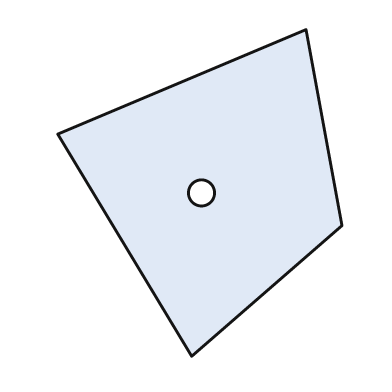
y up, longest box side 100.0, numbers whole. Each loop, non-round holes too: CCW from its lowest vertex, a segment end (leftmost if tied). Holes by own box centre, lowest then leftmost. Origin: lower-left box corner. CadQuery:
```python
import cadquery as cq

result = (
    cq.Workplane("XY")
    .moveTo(41.0, 0.0)
    .lineTo(87.0, 40.0)
    .lineTo(76.0, 100.0)
    .lineTo(0.0, 68.0)
    .close()
    .moveTo(44.0, 50.0)
    .circle(4.0)
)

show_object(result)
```